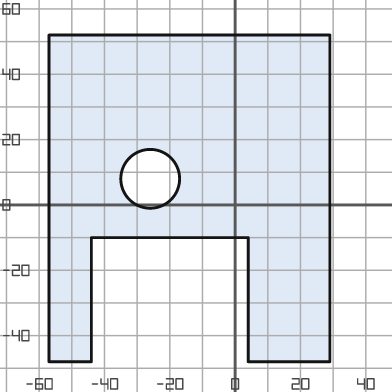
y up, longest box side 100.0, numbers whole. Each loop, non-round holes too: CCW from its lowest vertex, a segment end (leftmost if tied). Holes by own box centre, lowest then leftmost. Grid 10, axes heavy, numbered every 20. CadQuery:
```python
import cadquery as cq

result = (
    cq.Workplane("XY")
    .moveTo(-57.0, -48.0)
    .lineTo(-44.0, -48.0)
    .lineTo(-44.0, -10.0)
    .lineTo(4.0, -10.0)
    .lineTo(4.0, -48.0)
    .lineTo(29.0, -48.0)
    .lineTo(29.0, 52.0)
    .lineTo(-57.0, 52.0)
    .close()
    .moveTo(-26.0, 8.0)
    .circle(9.0)
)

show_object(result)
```